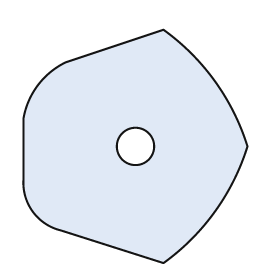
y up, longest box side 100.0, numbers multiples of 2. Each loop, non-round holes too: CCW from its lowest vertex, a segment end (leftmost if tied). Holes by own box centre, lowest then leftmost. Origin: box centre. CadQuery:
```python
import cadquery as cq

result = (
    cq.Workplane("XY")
    .moveTo(12.0, -50.0)
    .threePointArc((34.0, -28.0), (48.0, 0.0))
    .threePointArc((34.0, 28.0), (12.0, 50.0))
    .lineTo(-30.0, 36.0)
    .threePointArc((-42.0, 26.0), (-48.0, 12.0))
    .lineTo(-48.0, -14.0)
    .threePointArc((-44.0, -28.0), (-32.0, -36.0))
    .close()
    .moveTo(0.0, 0.0)
    .circle(8.0)
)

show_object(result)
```